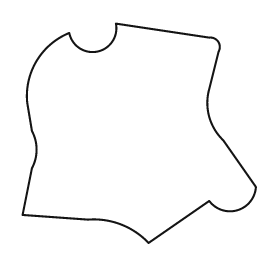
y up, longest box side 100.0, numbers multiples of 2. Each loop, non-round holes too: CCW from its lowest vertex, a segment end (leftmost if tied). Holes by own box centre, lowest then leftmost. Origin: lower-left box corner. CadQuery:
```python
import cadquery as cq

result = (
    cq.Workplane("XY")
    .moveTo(54.0, 0.0)
    .lineTo(80.0, 18.0)
    .threePointArc((92.0, 14.0), (100.0, 24.0))
    .lineTo(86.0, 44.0)
    .threePointArc((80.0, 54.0), (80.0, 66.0))
    .lineTo(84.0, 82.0)
    .threePointArc((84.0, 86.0), (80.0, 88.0))
    .lineTo(40.0, 94.0)
    .threePointArc((32.0, 82.0), (20.0, 90.0))
    .threePointArc((6.0, 78.0), (2.0, 60.0))
    .lineTo(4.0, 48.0)
    .threePointArc((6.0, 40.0), (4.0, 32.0))
    .lineTo(0.0, 12.0)
    .lineTo(28.0, 10.0)
    .threePointArc((42.0, 8.0), (54.0, 0.0))
    .close()
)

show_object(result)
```